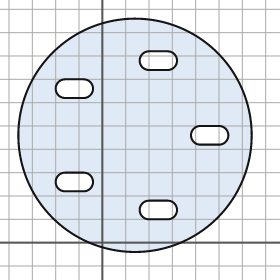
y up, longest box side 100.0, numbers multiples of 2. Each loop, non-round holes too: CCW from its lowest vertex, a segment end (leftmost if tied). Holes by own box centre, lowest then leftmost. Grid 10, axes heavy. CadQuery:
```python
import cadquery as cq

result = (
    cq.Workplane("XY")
    .moveTo(14.0, 46.0)
    .circle(50.0)
    .moveTo(20.0, 10.0)
    .lineTo(28.0, 10.0)
    .threePointArc((32.0, 14.0), (28.0, 18.0))
    .lineTo(20.0, 18.0)
    .threePointArc((16.0, 14.0), (20.0, 10.0))
    .close()
    .moveTo(-16.0, 22.0)
    .lineTo(-8.0, 22.0)
    .threePointArc((-4.0, 26.0), (-8.0, 30.0))
    .lineTo(-16.0, 30.0)
    .threePointArc((-20.0, 26.0), (-16.0, 22.0))
    .close()
    .moveTo(42.0, 42.0)
    .lineTo(50.0, 42.0)
    .threePointArc((54.0, 46.0), (50.0, 50.0))
    .lineTo(42.0, 50.0)
    .threePointArc((38.0, 46.0), (42.0, 42.0))
    .close()
    .moveTo(-16.0, 62.0)
    .lineTo(-8.0, 62.0)
    .threePointArc((-4.0, 66.0), (-8.0, 70.0))
    .lineTo(-16.0, 70.0)
    .threePointArc((-20.0, 66.0), (-16.0, 62.0))
    .close()
    .moveTo(20.0, 74.0)
    .lineTo(28.0, 74.0)
    .threePointArc((32.0, 78.0), (28.0, 82.0))
    .lineTo(20.0, 82.0)
    .threePointArc((16.0, 78.0), (20.0, 74.0))
    .close()
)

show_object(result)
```